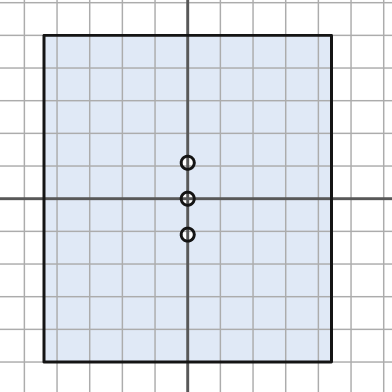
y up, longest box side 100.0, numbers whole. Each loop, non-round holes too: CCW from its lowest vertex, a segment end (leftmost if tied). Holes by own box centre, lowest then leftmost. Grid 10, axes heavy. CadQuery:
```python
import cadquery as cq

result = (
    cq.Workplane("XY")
    .moveTo(-44.0, -50.0)
    .lineTo(44.0, -50.0)
    .lineTo(44.0, 50.0)
    .lineTo(-44.0, 50.0)
    .close()
    .moveTo(0.0, -11.0)
    .circle(2.0)
    .moveTo(0.0, 0.0)
    .circle(2.0)
    .moveTo(0.0, 11.0)
    .circle(2.0)
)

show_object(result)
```